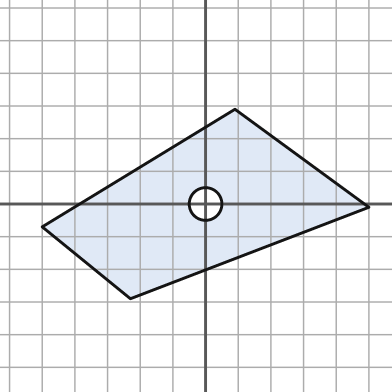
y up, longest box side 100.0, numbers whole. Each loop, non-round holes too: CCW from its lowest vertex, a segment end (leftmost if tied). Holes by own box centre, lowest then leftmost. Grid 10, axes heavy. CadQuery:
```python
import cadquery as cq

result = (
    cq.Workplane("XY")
    .moveTo(-23.0, -29.0)
    .lineTo(50.0, -1.0)
    .lineTo(9.0, 29.0)
    .lineTo(-50.0, -7.0)
    .close()
    .moveTo(0.0, 0.0)
    .circle(5.0)
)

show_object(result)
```